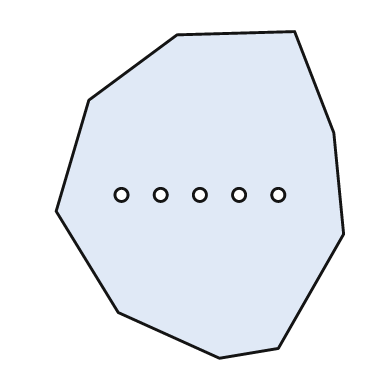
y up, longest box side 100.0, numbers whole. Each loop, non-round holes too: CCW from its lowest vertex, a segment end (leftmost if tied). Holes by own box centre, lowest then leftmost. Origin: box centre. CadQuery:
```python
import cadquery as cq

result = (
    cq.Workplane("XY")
    .moveTo(6.0, -50.0)
    .lineTo(24.0, -47.0)
    .lineTo(44.0, -12.0)
    .lineTo(41.0, 19.0)
    .lineTo(29.0, 50.0)
    .lineTo(-7.0, 49.0)
    .lineTo(-34.0, 29.0)
    .lineTo(-44.0, -5.0)
    .lineTo(-25.0, -36.0)
    .close()
    .moveTo(-24.0, 0.0)
    .circle(2.0)
    .moveTo(-12.0, 0.0)
    .circle(2.0)
    .moveTo(0.0, 0.0)
    .circle(2.0)
    .moveTo(12.0, 0.0)
    .circle(2.0)
    .moveTo(24.0, 0.0)
    .circle(2.0)
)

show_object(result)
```